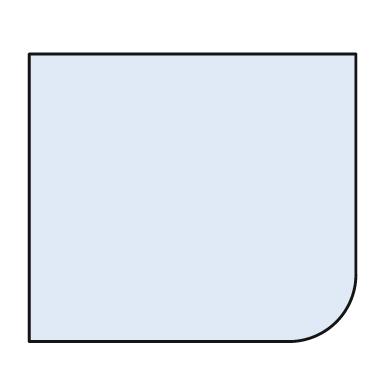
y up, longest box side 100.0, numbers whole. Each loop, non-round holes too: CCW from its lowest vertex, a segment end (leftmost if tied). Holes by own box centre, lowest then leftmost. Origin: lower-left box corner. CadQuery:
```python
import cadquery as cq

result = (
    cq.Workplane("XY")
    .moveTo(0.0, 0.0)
    .lineTo(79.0, 0.0)
    .threePointArc((94.0, 6.0), (100.0, 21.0))
    .lineTo(100.0, 88.0)
    .lineTo(0.0, 88.0)
    .close()
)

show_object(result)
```